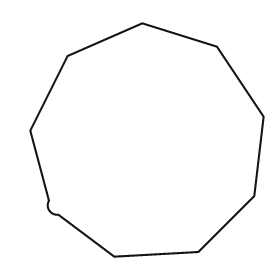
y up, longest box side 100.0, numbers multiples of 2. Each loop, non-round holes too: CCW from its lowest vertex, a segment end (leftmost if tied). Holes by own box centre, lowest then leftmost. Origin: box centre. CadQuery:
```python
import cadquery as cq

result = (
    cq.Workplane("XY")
    .moveTo(-14.0, -50.0)
    .lineTo(22.0, -48.0)
    .lineTo(46.0, -24.0)
    .lineTo(50.0, 10.0)
    .lineTo(30.0, 40.0)
    .lineTo(-2.0, 50.0)
    .lineTo(-34.0, 36.0)
    .lineTo(-50.0, 4.0)
    .lineTo(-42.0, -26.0)
    .threePointArc((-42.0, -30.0), (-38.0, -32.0))
    .close()
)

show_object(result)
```